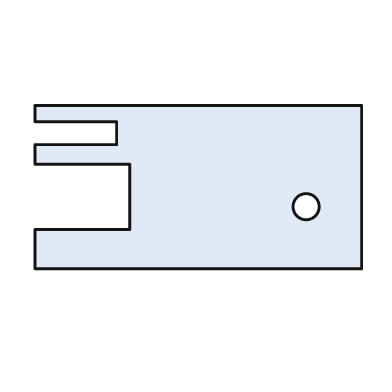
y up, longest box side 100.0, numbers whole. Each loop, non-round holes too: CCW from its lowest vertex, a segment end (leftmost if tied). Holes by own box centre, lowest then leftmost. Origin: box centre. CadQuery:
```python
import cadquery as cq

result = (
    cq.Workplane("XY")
    .moveTo(-50.0, -25.0)
    .lineTo(50.0, -25.0)
    .lineTo(50.0, 25.0)
    .lineTo(-50.0, 25.0)
    .lineTo(-50.0, 20.0)
    .lineTo(-25.0, 20.0)
    .lineTo(-25.0, 13.0)
    .lineTo(-50.0, 13.0)
    .lineTo(-50.0, 7.0)
    .lineTo(-21.0, 7.0)
    .lineTo(-21.0, -13.0)
    .lineTo(-50.0, -13.0)
    .close()
    .moveTo(33.0, -6.0)
    .circle(4.0)
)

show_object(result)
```